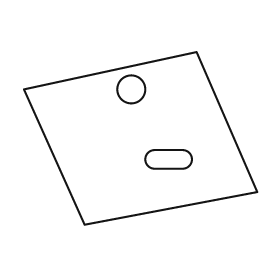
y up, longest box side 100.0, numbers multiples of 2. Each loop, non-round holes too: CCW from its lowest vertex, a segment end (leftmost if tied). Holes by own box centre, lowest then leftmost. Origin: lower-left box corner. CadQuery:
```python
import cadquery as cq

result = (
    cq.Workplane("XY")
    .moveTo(26.0, 0.0)
    .lineTo(100.0, 14.0)
    .lineTo(74.0, 74.0)
    .lineTo(0.0, 58.0)
    .close()
    .moveTo(56.0, 24.0)
    .lineTo(68.0, 24.0)
    .threePointArc((72.0, 28.0), (68.0, 32.0))
    .lineTo(56.0, 32.0)
    .threePointArc((52.0, 28.0), (56.0, 24.0))
    .close()
    .moveTo(46.0, 58.0)
    .circle(6.0)
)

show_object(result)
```